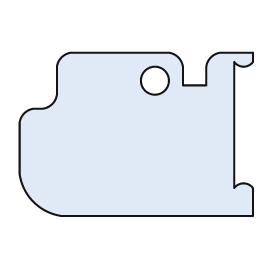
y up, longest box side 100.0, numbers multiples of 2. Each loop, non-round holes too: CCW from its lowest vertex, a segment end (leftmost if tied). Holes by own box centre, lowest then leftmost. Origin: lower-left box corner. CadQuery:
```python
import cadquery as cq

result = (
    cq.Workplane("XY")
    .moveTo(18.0, 0.0)
    .lineTo(100.0, 0.0)
    .lineTo(100.0, 12.0)
    .threePointArc((96.0, 14.0), (92.0, 12.0))
    .lineTo(92.0, 66.0)
    .threePointArc((96.0, 64.0), (100.0, 66.0))
    .lineTo(100.0, 70.0)
    .lineTo(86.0, 70.0)
    .threePointArc((82.0, 68.0), (80.0, 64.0))
    .lineTo(80.0, 56.0)
    .lineTo(70.0, 56.0)
    .lineTo(70.0, 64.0)
    .threePointArc((68.0, 68.0), (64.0, 70.0))
    .lineTo(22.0, 70.0)
    .threePointArc((18.0, 68.0), (16.0, 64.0))
    .lineTo(16.0, 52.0)
    .threePointArc((14.0, 48.0), (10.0, 46.0))
    .lineTo(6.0, 46.0)
    .threePointArc((2.0, 44.0), (0.0, 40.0))
    .lineTo(0.0, 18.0)
    .threePointArc((6.0, 6.0), (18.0, 0.0))
    .close()
    .moveTo(58.0, 58.0)
    .circle(6.0)
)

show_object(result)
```